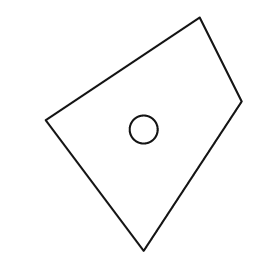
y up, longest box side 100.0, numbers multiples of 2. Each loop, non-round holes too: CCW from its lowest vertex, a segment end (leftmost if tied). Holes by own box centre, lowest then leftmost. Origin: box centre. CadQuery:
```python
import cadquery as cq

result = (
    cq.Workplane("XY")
    .moveTo(0.0, -50.0)
    .lineTo(42.0, 14.0)
    .lineTo(24.0, 50.0)
    .lineTo(-42.0, 6.0)
    .close()
    .moveTo(0.0, 2.0)
    .circle(6.0)
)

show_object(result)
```